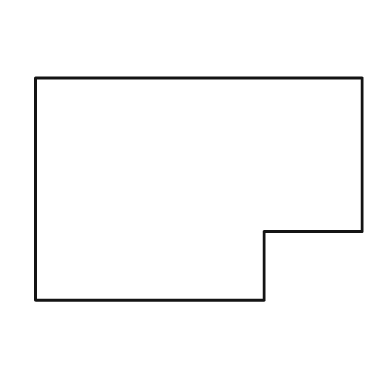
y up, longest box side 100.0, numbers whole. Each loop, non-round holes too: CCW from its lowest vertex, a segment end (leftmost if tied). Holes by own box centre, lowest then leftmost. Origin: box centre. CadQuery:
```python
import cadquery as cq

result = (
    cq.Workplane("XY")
    .moveTo(-50.0, -34.0)
    .lineTo(20.0, -34.0)
    .lineTo(20.0, -13.0)
    .lineTo(50.0, -13.0)
    .lineTo(50.0, 34.0)
    .lineTo(-50.0, 34.0)
    .close()
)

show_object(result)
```